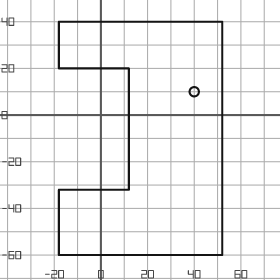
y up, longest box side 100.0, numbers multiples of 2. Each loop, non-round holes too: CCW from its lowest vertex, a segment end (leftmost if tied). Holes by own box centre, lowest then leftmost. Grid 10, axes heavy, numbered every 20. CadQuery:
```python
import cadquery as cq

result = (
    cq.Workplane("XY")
    .moveTo(-18.0, -60.0)
    .lineTo(52.0, -60.0)
    .lineTo(52.0, 40.0)
    .lineTo(-18.0, 40.0)
    .lineTo(-18.0, 20.0)
    .lineTo(12.0, 20.0)
    .lineTo(12.0, -32.0)
    .lineTo(-18.0, -32.0)
    .close()
    .moveTo(40.0, 10.0)
    .circle(2.0)
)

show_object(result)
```